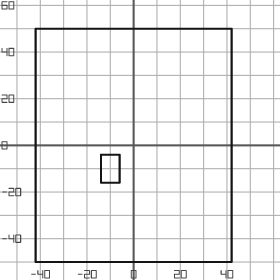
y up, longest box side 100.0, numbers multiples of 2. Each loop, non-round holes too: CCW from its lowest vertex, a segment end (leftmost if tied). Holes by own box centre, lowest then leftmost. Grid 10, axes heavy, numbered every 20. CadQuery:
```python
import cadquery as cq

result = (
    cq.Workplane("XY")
    .moveTo(-42.0, -50.0)
    .lineTo(42.0, -50.0)
    .lineTo(42.0, 50.0)
    .lineTo(-42.0, 50.0)
    .close()
    .moveTo(-14.0, -16.0)
    .lineTo(-6.0, -16.0)
    .lineTo(-6.0, -4.0)
    .lineTo(-14.0, -4.0)
    .close()
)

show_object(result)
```